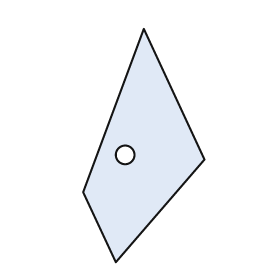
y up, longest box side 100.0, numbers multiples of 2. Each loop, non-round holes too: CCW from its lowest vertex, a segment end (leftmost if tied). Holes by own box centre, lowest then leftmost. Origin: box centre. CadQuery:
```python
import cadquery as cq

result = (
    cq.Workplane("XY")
    .moveTo(-12.0, -50.0)
    .lineTo(26.0, -6.0)
    .lineTo(0.0, 50.0)
    .lineTo(-26.0, -20.0)
    .close()
    .moveTo(-8.0, -4.0)
    .circle(4.0)
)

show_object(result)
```